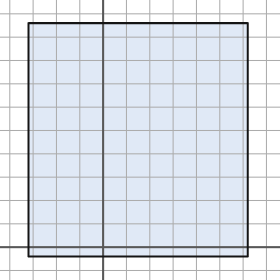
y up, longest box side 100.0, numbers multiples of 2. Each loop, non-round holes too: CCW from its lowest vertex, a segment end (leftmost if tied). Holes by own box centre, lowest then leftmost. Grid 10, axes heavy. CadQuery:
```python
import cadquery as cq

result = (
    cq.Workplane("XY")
    .moveTo(-32.0, -4.0)
    .lineTo(62.0, -4.0)
    .lineTo(62.0, 96.0)
    .lineTo(-32.0, 96.0)
    .close()
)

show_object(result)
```